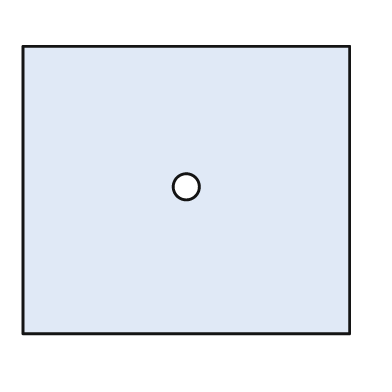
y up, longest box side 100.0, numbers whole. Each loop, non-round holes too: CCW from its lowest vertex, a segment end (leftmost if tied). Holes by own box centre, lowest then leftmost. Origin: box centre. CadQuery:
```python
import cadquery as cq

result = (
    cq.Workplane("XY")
    .moveTo(-50.0, -44.0)
    .lineTo(50.0, -44.0)
    .lineTo(50.0, 44.0)
    .lineTo(-50.0, 44.0)
    .close()
    .moveTo(0.0, 1.0)
    .circle(4.0)
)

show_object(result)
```